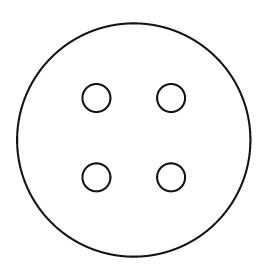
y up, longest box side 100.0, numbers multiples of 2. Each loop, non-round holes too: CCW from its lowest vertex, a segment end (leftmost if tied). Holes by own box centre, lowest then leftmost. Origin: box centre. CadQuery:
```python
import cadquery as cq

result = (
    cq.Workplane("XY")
    .moveTo(0.0, 0.0)
    .circle(50.0)
    .moveTo(-16.0, -16.0)
    .circle(6.0)
    .moveTo(16.0, -16.0)
    .circle(6.0)
    .moveTo(-16.0, 18.0)
    .circle(6.0)
    .moveTo(16.0, 18.0)
    .circle(6.0)
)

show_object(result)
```